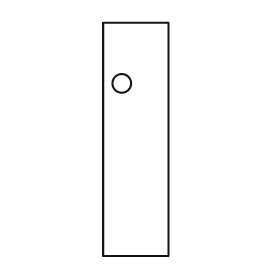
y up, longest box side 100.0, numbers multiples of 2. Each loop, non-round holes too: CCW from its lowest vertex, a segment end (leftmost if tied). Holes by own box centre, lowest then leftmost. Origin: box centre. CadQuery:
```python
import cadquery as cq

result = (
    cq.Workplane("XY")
    .moveTo(-14.0, -50.0)
    .lineTo(14.0, -50.0)
    .lineTo(14.0, 50.0)
    .lineTo(-14.0, 50.0)
    .close()
    .moveTo(-6.0, 24.0)
    .circle(4.0)
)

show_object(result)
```